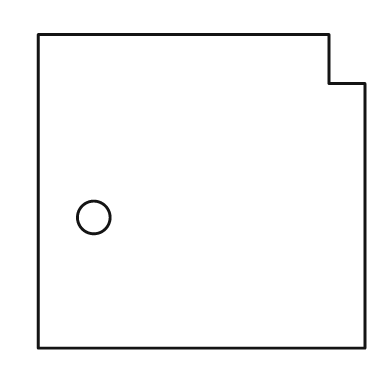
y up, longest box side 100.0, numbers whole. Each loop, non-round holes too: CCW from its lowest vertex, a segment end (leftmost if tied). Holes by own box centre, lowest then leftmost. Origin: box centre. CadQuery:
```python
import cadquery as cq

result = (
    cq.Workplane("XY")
    .moveTo(-50.0, -48.0)
    .lineTo(50.0, -48.0)
    .lineTo(50.0, 33.0)
    .lineTo(39.0, 33.0)
    .lineTo(39.0, 48.0)
    .lineTo(-50.0, 48.0)
    .close()
    .moveTo(-33.0, -8.0)
    .circle(5.0)
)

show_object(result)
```